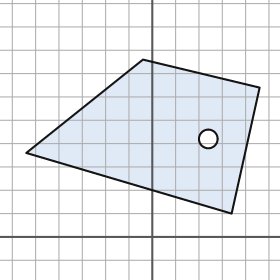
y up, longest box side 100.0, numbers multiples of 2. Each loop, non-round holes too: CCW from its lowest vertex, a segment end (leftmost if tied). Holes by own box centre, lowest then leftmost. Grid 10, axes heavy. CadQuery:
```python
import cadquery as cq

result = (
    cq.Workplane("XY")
    .moveTo(34.0, 10.0)
    .lineTo(46.0, 64.0)
    .lineTo(-4.0, 76.0)
    .lineTo(-54.0, 36.0)
    .close()
    .moveTo(24.0, 42.0)
    .circle(4.0)
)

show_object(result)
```